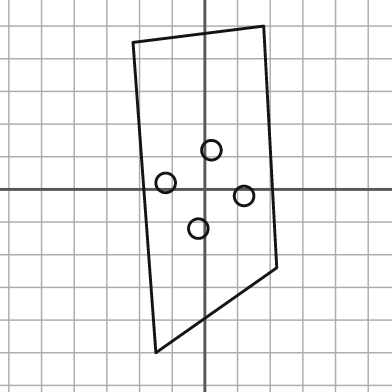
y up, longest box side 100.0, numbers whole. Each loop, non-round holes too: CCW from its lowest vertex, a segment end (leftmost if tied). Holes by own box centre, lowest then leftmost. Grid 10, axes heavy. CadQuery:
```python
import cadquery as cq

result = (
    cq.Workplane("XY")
    .moveTo(-15.0, -50.0)
    .lineTo(22.0, -24.0)
    .lineTo(18.0, 50.0)
    .lineTo(-22.0, 45.0)
    .close()
    .moveTo(-2.0, -12.0)
    .circle(3.0)
    .moveTo(12.0, -2.0)
    .circle(3.0)
    .moveTo(-12.0, 2.0)
    .circle(3.0)
    .moveTo(2.0, 12.0)
    .circle(3.0)
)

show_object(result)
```